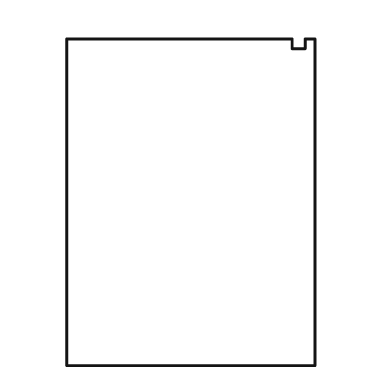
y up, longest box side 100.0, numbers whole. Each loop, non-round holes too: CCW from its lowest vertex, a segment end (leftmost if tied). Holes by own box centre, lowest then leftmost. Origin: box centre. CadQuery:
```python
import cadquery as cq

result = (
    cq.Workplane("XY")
    .moveTo(-38.0, -50.0)
    .lineTo(38.0, -50.0)
    .lineTo(38.0, 50.0)
    .lineTo(35.0, 50.0)
    .lineTo(35.0, 47.0)
    .lineTo(31.0, 47.0)
    .lineTo(31.0, 50.0)
    .lineTo(-38.0, 50.0)
    .close()
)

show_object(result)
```